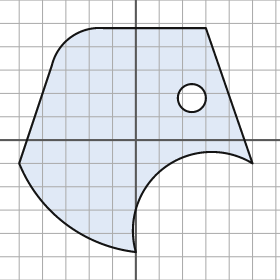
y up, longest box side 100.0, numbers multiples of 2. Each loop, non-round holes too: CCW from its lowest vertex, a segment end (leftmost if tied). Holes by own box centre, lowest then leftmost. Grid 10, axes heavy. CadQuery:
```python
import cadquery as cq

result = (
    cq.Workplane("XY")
    .moveTo(0.0, -48.0)
    .threePointArc((12.0, -12.0), (50.0, -10.0))
    .lineTo(30.0, 48.0)
    .lineTo(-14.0, 48.0)
    .threePointArc((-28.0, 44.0), (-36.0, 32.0))
    .lineTo(-50.0, -10.0)
    .threePointArc((-30.0, -36.0), (0.0, -48.0))
    .close()
    .moveTo(24.0, 18.0)
    .circle(6.0)
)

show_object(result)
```